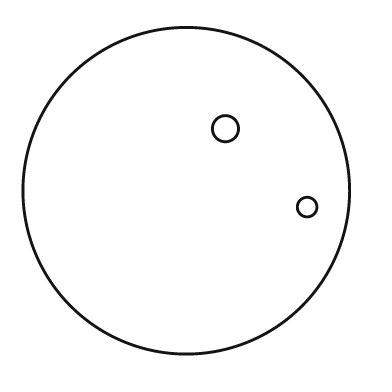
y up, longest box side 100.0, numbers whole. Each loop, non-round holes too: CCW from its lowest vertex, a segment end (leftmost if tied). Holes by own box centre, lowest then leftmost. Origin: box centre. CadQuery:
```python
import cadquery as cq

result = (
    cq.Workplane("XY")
    .moveTo(0.0, 0.0)
    .circle(50.0)
    .moveTo(37.0, -5.0)
    .circle(3.0)
    .moveTo(12.0, 19.0)
    .circle(4.0)
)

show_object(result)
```